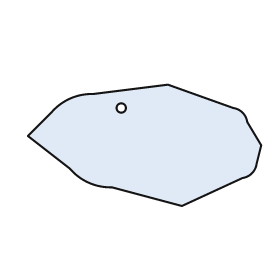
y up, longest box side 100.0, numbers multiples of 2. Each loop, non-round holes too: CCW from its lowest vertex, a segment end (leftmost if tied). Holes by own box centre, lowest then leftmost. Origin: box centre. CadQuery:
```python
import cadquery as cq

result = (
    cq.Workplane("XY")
    .moveTo(16.0, -26.0)
    .lineTo(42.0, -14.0)
    .threePointArc((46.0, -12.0), (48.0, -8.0))
    .lineTo(50.0, 0.0)
    .lineTo(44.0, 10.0)
    .threePointArc((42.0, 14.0), (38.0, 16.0))
    .lineTo(10.0, 26.0)
    .lineTo(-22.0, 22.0)
    .threePointArc((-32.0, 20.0), (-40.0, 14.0))
    .lineTo(-50.0, 4.0)
    .lineTo(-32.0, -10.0)
    .threePointArc((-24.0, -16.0), (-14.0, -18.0))
    .close()
    .moveTo(-10.0, 16.0)
    .circle(2.0)
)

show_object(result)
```